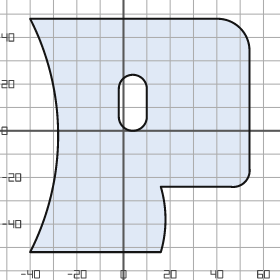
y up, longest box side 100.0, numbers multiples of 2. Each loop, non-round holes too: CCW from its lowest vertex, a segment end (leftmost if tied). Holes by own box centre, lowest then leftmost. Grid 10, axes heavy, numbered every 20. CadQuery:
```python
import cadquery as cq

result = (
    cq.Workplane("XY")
    .moveTo(-40.0, -52.0)
    .lineTo(16.0, -52.0)
    .threePointArc((18.0, -38.0), (16.0, -24.0))
    .lineTo(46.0, -24.0)
    .threePointArc((52.0, -22.0), (54.0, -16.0))
    .lineTo(54.0, 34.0)
    .threePointArc((50.0, 44.0), (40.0, 48.0))
    .lineTo(-40.0, 48.0)
    .threePointArc((-28.0, -2.0), (-40.0, -52.0))
    .close()
    .moveTo(-2.0, 6.0)
    .threePointArc((4.0, 0.0), (10.0, 6.0))
    .lineTo(10.0, 18.0)
    .threePointArc((4.0, 24.0), (-2.0, 18.0))
    .close()
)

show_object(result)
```